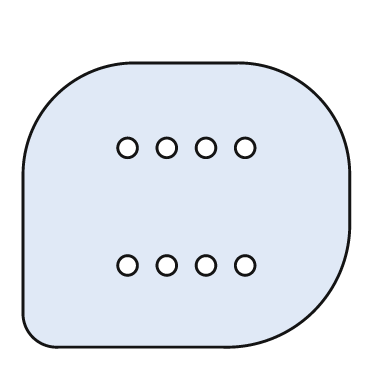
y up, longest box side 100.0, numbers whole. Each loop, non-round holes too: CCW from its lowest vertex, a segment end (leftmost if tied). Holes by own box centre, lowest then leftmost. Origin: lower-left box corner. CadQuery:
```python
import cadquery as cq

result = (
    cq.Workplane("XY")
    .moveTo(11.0, 0.0)
    .lineTo(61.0, 0.0)
    .threePointArc((89.0, 11.0), (100.0, 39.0))
    .lineTo(100.0, 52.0)
    .threePointArc((90.0, 77.0), (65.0, 87.0))
    .lineTo(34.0, 87.0)
    .threePointArc((10.0, 77.0), (0.0, 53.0))
    .lineTo(0.0, 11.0)
    .threePointArc((3.0, 3.0), (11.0, 0.0))
    .close()
    .moveTo(32.0, 25.0)
    .circle(3.0)
    .moveTo(44.0, 25.0)
    .circle(3.0)
    .moveTo(56.0, 25.0)
    .circle(3.0)
    .moveTo(68.0, 25.0)
    .circle(3.0)
    .moveTo(32.0, 61.0)
    .circle(3.0)
    .moveTo(44.0, 61.0)
    .circle(3.0)
    .moveTo(56.0, 61.0)
    .circle(3.0)
    .moveTo(68.0, 61.0)
    .circle(3.0)
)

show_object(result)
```